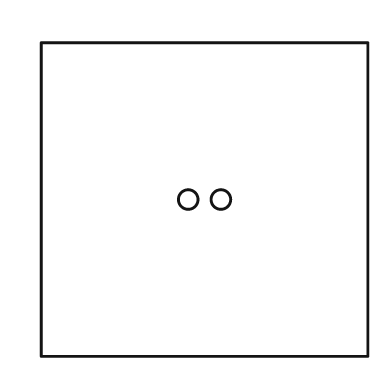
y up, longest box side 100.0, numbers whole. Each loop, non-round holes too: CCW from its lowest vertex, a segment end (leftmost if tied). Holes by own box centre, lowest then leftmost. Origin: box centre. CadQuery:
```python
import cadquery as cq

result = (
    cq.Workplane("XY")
    .moveTo(-50.0, -48.0)
    .lineTo(50.0, -48.0)
    .lineTo(50.0, 48.0)
    .lineTo(-50.0, 48.0)
    .close()
    .moveTo(-5.0, 0.0)
    .circle(3.0)
    .moveTo(5.0, 0.0)
    .circle(3.0)
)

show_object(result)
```